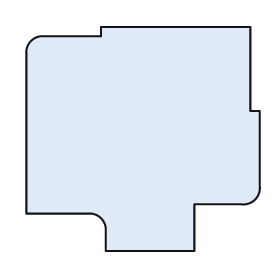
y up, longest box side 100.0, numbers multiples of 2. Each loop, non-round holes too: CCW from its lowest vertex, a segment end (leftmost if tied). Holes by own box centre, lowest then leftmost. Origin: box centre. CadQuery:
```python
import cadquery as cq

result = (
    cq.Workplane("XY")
    .moveTo(-16.0, -48.0)
    .lineTo(22.0, -48.0)
    .lineTo(22.0, -28.0)
    .lineTo(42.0, -28.0)
    .threePointArc((48.0, -26.0), (50.0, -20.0))
    .lineTo(50.0, 12.0)
    .lineTo(46.0, 12.0)
    .lineTo(46.0, 48.0)
    .lineTo(-18.0, 48.0)
    .lineTo(-18.0, 44.0)
    .lineTo(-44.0, 44.0)
    .threePointArc((-48.0, 42.0), (-50.0, 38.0))
    .lineTo(-50.0, -32.0)
    .lineTo(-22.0, -32.0)
    .threePointArc((-18.0, -34.0), (-16.0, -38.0))
    .close()
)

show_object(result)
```